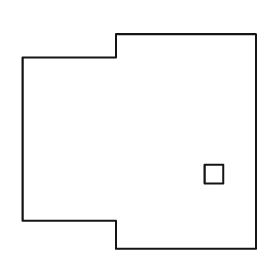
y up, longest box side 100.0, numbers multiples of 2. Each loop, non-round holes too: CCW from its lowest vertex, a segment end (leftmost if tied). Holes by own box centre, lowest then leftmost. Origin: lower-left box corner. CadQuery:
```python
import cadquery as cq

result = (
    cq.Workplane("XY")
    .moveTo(40.0, 0.0)
    .lineTo(100.0, 0.0)
    .lineTo(100.0, 92.0)
    .lineTo(40.0, 92.0)
    .lineTo(40.0, 82.0)
    .lineTo(0.0, 82.0)
    .lineTo(0.0, 12.0)
    .lineTo(40.0, 12.0)
    .close()
    .moveTo(78.0, 28.0)
    .lineTo(86.0, 28.0)
    .lineTo(86.0, 36.0)
    .lineTo(78.0, 36.0)
    .close()
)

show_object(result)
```